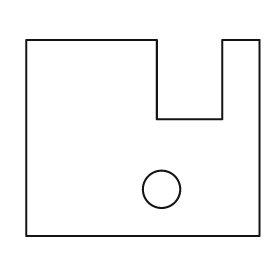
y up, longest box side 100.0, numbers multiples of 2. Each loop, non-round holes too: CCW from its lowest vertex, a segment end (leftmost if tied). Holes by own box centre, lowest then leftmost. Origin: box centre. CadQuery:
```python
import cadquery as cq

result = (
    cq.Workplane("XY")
    .moveTo(-50.0, -42.0)
    .lineTo(50.0, -42.0)
    .lineTo(50.0, 42.0)
    .lineTo(34.0, 42.0)
    .lineTo(34.0, 8.0)
    .lineTo(6.0, 8.0)
    .lineTo(6.0, 42.0)
    .lineTo(-50.0, 42.0)
    .close()
    .moveTo(8.0, -22.0)
    .circle(8.0)
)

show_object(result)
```